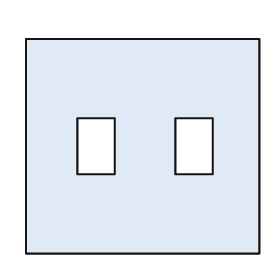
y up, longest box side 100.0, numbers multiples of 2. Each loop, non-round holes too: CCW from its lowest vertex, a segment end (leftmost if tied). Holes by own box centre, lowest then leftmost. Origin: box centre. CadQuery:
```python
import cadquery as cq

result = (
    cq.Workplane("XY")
    .moveTo(-50.0, -46.0)
    .lineTo(50.0, -46.0)
    .lineTo(50.0, 46.0)
    .lineTo(-50.0, 46.0)
    .close()
    .moveTo(-28.0, -12.0)
    .lineTo(-12.0, -12.0)
    .lineTo(-12.0, 12.0)
    .lineTo(-28.0, 12.0)
    .close()
    .moveTo(14.0, -12.0)
    .lineTo(30.0, -12.0)
    .lineTo(30.0, 12.0)
    .lineTo(14.0, 12.0)
    .close()
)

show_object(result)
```